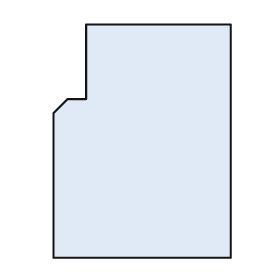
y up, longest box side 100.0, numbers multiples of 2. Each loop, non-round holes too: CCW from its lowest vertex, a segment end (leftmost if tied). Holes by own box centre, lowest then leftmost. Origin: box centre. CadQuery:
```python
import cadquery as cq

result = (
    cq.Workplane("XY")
    .moveTo(-38.0, -50.0)
    .lineTo(38.0, -50.0)
    .lineTo(38.0, 50.0)
    .lineTo(-24.0, 50.0)
    .lineTo(-24.0, 18.0)
    .lineTo(-32.0, 18.0)
    .lineTo(-38.0, 12.0)
    .close()
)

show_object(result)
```